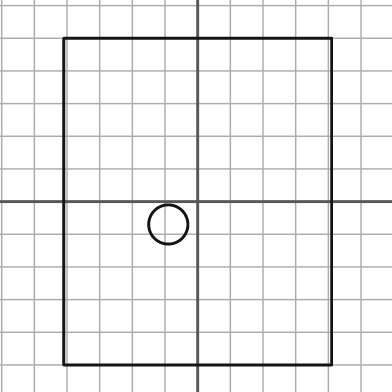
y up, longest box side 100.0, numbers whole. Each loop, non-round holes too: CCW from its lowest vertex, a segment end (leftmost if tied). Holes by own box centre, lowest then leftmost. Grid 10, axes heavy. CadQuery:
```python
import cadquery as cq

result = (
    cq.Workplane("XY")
    .moveTo(-41.0, -50.0)
    .lineTo(41.0, -50.0)
    .lineTo(41.0, 50.0)
    .lineTo(-41.0, 50.0)
    .close()
    .moveTo(-9.0, -7.0)
    .circle(6.0)
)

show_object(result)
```